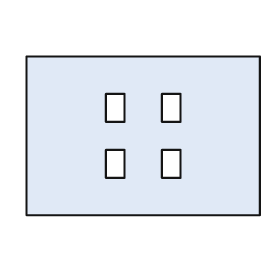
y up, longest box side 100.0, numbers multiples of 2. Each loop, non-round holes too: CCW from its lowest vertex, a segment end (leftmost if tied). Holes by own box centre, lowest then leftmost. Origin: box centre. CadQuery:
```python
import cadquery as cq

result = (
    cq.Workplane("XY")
    .moveTo(-50.0, -34.0)
    .lineTo(50.0, -34.0)
    .lineTo(50.0, 34.0)
    .lineTo(-50.0, 34.0)
    .close()
    .moveTo(-16.0, -18.0)
    .lineTo(-8.0, -18.0)
    .lineTo(-8.0, -6.0)
    .lineTo(-16.0, -6.0)
    .close()
    .moveTo(8.0, -18.0)
    .lineTo(16.0, -18.0)
    .lineTo(16.0, -6.0)
    .lineTo(8.0, -6.0)
    .close()
    .moveTo(-16.0, 6.0)
    .lineTo(-8.0, 6.0)
    .lineTo(-8.0, 18.0)
    .lineTo(-16.0, 18.0)
    .close()
    .moveTo(8.0, 6.0)
    .lineTo(16.0, 6.0)
    .lineTo(16.0, 18.0)
    .lineTo(8.0, 18.0)
    .close()
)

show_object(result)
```